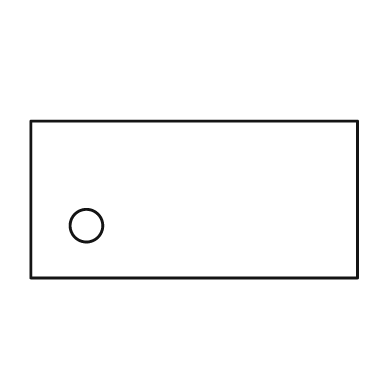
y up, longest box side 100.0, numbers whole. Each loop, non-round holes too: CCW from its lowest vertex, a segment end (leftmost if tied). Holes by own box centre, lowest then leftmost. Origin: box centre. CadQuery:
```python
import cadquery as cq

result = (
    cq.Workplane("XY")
    .moveTo(-50.0, -24.0)
    .lineTo(50.0, -24.0)
    .lineTo(50.0, 24.0)
    .lineTo(-50.0, 24.0)
    .close()
    .moveTo(-33.0, -8.0)
    .circle(5.0)
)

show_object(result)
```